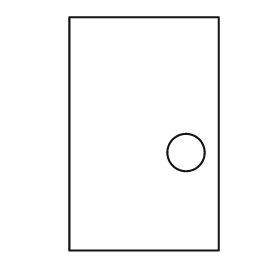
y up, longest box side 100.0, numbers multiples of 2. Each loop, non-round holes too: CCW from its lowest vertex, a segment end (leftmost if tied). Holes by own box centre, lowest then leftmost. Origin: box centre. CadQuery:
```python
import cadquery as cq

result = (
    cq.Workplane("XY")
    .moveTo(-32.0, -50.0)
    .lineTo(32.0, -50.0)
    .lineTo(32.0, 50.0)
    .lineTo(-32.0, 50.0)
    .close()
    .moveTo(18.0, -8.0)
    .circle(8.0)
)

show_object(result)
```